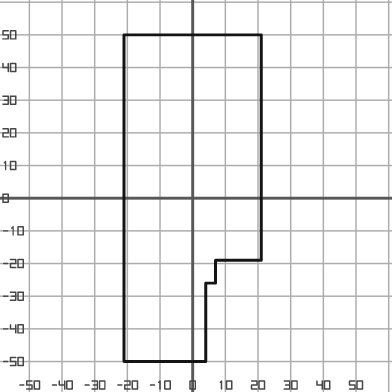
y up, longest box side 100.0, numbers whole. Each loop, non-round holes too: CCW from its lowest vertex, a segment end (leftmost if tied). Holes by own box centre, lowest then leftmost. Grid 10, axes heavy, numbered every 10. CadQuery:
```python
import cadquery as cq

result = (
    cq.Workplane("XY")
    .moveTo(-21.0, -50.0)
    .lineTo(4.0, -50.0)
    .lineTo(4.0, -26.0)
    .lineTo(7.0, -26.0)
    .lineTo(7.0, -19.0)
    .lineTo(21.0, -19.0)
    .lineTo(21.0, 50.0)
    .lineTo(-21.0, 50.0)
    .close()
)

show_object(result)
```